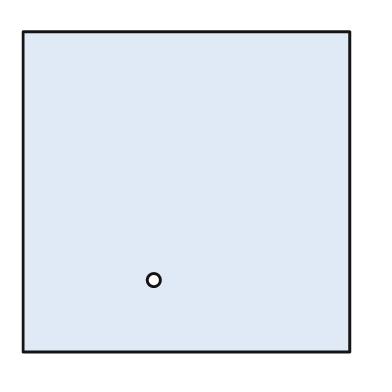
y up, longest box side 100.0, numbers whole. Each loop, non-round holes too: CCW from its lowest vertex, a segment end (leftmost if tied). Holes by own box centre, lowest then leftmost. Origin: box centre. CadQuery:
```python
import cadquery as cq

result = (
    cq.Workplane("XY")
    .moveTo(-50.0, -49.0)
    .lineTo(50.0, -49.0)
    .lineTo(50.0, 49.0)
    .lineTo(-50.0, 49.0)
    .close()
    .moveTo(-10.0, -27.0)
    .circle(2.0)
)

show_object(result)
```